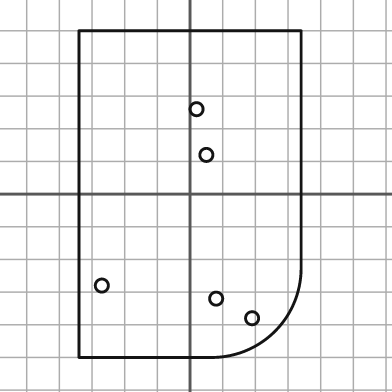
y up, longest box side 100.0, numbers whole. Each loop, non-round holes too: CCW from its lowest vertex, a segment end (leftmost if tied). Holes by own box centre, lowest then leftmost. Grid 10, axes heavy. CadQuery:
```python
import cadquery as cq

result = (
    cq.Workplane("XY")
    .moveTo(-34.0, -50.0)
    .lineTo(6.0, -50.0)
    .threePointArc((26.0, -42.0), (34.0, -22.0))
    .lineTo(34.0, 50.0)
    .lineTo(-34.0, 50.0)
    .close()
    .moveTo(19.0, -38.0)
    .circle(2.0)
    .moveTo(8.0, -32.0)
    .circle(2.0)
    .moveTo(-27.0, -28.0)
    .circle(2.0)
    .moveTo(5.0, 12.0)
    .circle(2.0)
    .moveTo(2.0, 26.0)
    .circle(2.0)
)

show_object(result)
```